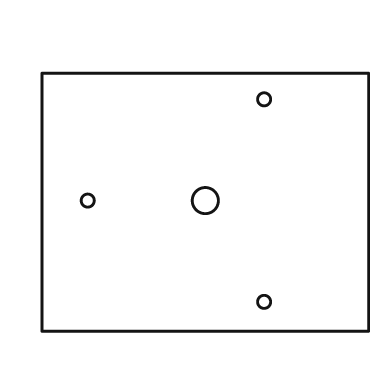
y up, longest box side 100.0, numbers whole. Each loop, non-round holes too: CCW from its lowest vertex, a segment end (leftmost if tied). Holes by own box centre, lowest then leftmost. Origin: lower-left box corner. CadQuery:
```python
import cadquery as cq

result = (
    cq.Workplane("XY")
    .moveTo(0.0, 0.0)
    .lineTo(100.0, 0.0)
    .lineTo(100.0, 79.0)
    .lineTo(0.0, 79.0)
    .close()
    .moveTo(68.0, 9.0)
    .circle(2.0)
    .moveTo(14.0, 40.0)
    .circle(2.0)
    .moveTo(50.0, 40.0)
    .circle(4.0)
    .moveTo(68.0, 71.0)
    .circle(2.0)
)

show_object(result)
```